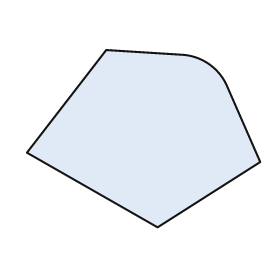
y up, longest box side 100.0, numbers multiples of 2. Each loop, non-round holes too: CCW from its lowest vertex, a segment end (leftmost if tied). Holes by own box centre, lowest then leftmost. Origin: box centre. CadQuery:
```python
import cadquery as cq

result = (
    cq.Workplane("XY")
    .moveTo(6.0, -38.0)
    .lineTo(50.0, -10.0)
    .lineTo(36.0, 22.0)
    .threePointArc((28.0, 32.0), (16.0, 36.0))
    .lineTo(-16.0, 38.0)
    .lineTo(-50.0, -6.0)
    .close()
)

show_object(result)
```